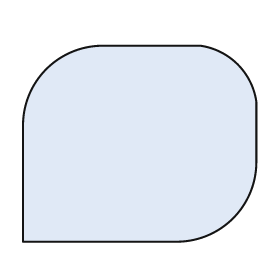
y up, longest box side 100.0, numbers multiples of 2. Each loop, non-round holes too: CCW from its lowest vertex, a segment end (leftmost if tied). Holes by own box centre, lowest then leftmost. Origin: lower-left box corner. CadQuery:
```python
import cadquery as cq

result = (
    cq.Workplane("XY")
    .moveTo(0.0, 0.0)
    .lineTo(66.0, 0.0)
    .threePointArc((90.0, 10.0), (100.0, 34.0))
    .lineTo(100.0, 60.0)
    .threePointArc((92.0, 76.0), (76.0, 84.0))
    .lineTo(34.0, 84.0)
    .threePointArc((10.0, 74.0), (0.0, 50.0))
    .close()
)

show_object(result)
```